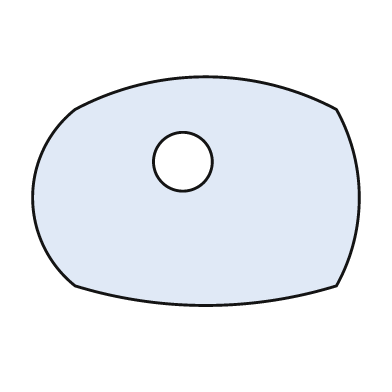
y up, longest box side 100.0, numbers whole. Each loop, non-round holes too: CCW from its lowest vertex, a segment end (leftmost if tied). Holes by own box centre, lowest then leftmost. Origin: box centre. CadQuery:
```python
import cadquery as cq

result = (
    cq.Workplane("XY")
    .moveTo(-37.0, -29.0)
    .threePointArc((3.0, -35.0), (43.0, -29.0))
    .threePointArc((50.0, -2.0), (43.0, 25.0))
    .threePointArc((3.0, 35.0), (-37.0, 25.0))
    .threePointArc((-50.0, -2.0), (-37.0, -29.0))
    .close()
    .moveTo(-4.0, 9.0)
    .circle(9.0)
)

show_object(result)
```